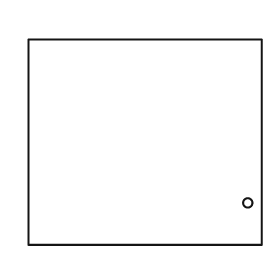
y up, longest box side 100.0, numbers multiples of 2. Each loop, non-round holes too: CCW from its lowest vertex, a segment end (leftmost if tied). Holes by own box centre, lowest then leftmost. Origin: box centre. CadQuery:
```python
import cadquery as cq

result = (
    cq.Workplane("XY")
    .moveTo(-50.0, -44.0)
    .lineTo(50.0, -44.0)
    .lineTo(50.0, 44.0)
    .lineTo(-50.0, 44.0)
    .close()
    .moveTo(44.0, -26.0)
    .circle(2.0)
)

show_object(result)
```